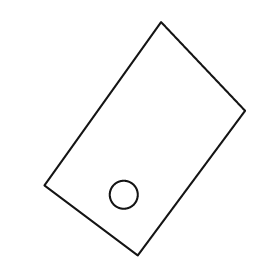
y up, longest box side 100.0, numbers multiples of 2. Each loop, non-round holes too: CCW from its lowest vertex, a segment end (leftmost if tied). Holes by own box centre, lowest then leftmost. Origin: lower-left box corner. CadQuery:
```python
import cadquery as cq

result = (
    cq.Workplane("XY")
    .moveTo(40.0, 0.0)
    .lineTo(86.0, 62.0)
    .lineTo(50.0, 100.0)
    .lineTo(0.0, 30.0)
    .close()
    .moveTo(34.0, 26.0)
    .circle(6.0)
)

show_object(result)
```